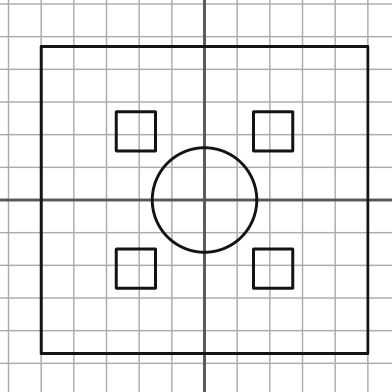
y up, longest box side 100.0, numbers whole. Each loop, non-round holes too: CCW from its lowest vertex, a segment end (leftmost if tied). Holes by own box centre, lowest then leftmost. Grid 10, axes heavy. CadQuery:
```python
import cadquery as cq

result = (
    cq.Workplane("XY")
    .moveTo(-50.0, -47.0)
    .lineTo(50.0, -47.0)
    .lineTo(50.0, 47.0)
    .lineTo(-50.0, 47.0)
    .close()
    .moveTo(-27.0, -27.0)
    .lineTo(-15.0, -27.0)
    .lineTo(-15.0, -15.0)
    .lineTo(-27.0, -15.0)
    .close()
    .moveTo(15.0, -27.0)
    .lineTo(27.0, -27.0)
    .lineTo(27.0, -15.0)
    .lineTo(15.0, -15.0)
    .close()
    .moveTo(0.0, 0.0)
    .circle(16.0)
    .moveTo(-27.0, 15.0)
    .lineTo(-15.0, 15.0)
    .lineTo(-15.0, 27.0)
    .lineTo(-27.0, 27.0)
    .close()
    .moveTo(15.0, 15.0)
    .lineTo(27.0, 15.0)
    .lineTo(27.0, 27.0)
    .lineTo(15.0, 27.0)
    .close()
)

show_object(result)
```